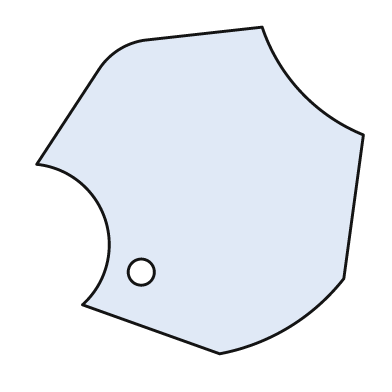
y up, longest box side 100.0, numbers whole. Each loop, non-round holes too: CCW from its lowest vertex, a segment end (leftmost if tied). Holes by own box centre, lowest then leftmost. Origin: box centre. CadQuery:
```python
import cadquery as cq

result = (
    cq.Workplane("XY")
    .moveTo(6.0, -50.0)
    .threePointArc((27.0, -42.0), (44.0, -27.0))
    .lineTo(50.0, 17.0)
    .threePointArc((31.0, 30.0), (19.0, 50.0))
    .lineTo(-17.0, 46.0)
    .threePointArc((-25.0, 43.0), (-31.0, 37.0))
    .lineTo(-50.0, 8.0)
    .threePointArc((-29.0, -9.0), (-36.0, -35.0))
    .close()
    .moveTo(-18.0, -25.0)
    .circle(4.0)
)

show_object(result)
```